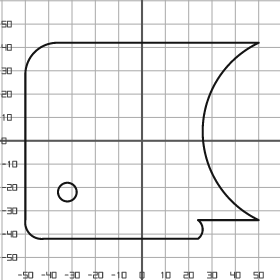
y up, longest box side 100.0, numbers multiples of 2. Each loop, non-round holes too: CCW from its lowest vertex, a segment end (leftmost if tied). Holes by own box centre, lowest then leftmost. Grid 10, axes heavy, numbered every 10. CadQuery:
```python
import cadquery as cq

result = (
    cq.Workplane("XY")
    .moveTo(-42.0, -42.0)
    .lineTo(24.0, -42.0)
    .threePointArc((26.0, -38.0), (24.0, -34.0))
    .lineTo(50.0, -34.0)
    .threePointArc((26.0, 4.0), (50.0, 42.0))
    .lineTo(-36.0, 42.0)
    .threePointArc((-46.0, 38.0), (-50.0, 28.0))
    .lineTo(-50.0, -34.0)
    .threePointArc((-48.0, -40.0), (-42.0, -42.0))
    .close()
    .moveTo(-32.0, -22.0)
    .circle(4.0)
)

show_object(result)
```